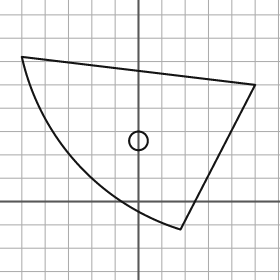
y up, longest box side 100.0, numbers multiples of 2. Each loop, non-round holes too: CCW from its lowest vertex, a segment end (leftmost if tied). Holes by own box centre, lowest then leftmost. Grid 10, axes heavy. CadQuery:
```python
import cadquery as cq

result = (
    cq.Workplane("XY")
    .moveTo(18.0, -12.0)
    .lineTo(50.0, 50.0)
    .lineTo(-50.0, 62.0)
    .threePointArc((-26.0, 16.0), (18.0, -12.0))
    .close()
    .moveTo(0.0, 26.0)
    .circle(4.0)
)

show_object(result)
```